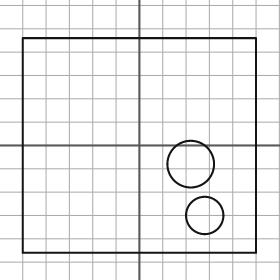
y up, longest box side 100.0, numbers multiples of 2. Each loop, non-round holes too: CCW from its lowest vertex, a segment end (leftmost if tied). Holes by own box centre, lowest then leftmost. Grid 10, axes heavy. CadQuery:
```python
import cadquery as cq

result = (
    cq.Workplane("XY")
    .moveTo(-50.0, -46.0)
    .lineTo(50.0, -46.0)
    .lineTo(50.0, 46.0)
    .lineTo(-50.0, 46.0)
    .close()
    .moveTo(28.0, -30.0)
    .circle(8.0)
    .moveTo(22.0, -8.0)
    .circle(10.0)
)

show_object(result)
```